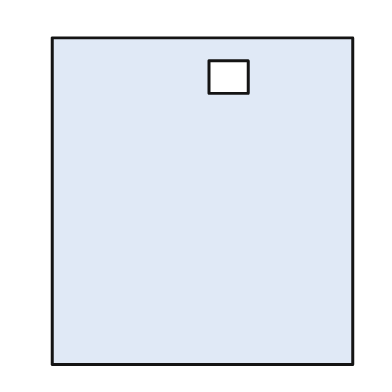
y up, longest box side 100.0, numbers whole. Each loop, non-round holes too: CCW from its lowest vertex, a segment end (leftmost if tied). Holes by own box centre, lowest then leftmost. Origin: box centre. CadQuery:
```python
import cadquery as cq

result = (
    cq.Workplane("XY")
    .moveTo(-46.0, -50.0)
    .lineTo(46.0, -50.0)
    .lineTo(46.0, 50.0)
    .lineTo(-46.0, 50.0)
    .close()
    .moveTo(2.0, 33.0)
    .lineTo(14.0, 33.0)
    .lineTo(14.0, 43.0)
    .lineTo(2.0, 43.0)
    .close()
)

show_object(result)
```